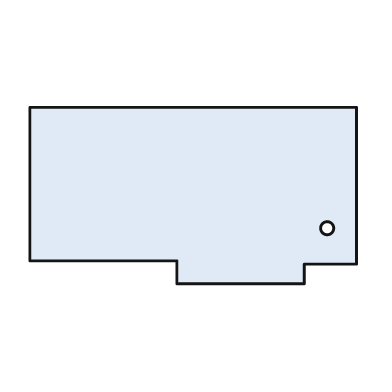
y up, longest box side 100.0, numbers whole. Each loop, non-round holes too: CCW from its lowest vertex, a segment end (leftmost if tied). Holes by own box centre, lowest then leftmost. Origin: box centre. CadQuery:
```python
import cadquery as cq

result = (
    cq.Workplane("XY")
    .moveTo(-5.0, -27.0)
    .lineTo(34.0, -27.0)
    .lineTo(34.0, -21.0)
    .lineTo(50.0, -21.0)
    .lineTo(50.0, 27.0)
    .lineTo(-50.0, 27.0)
    .lineTo(-50.0, -20.0)
    .lineTo(-5.0, -20.0)
    .close()
    .moveTo(41.0, -10.0)
    .circle(2.0)
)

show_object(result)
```